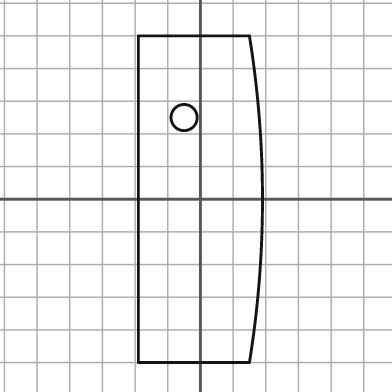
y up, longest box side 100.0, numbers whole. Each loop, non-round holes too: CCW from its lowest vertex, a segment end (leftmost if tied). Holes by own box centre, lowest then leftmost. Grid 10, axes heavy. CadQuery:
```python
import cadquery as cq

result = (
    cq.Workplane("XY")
    .moveTo(-19.0, -50.0)
    .lineTo(15.0, -50.0)
    .threePointArc((19.0, 0.0), (15.0, 50.0))
    .lineTo(-19.0, 50.0)
    .close()
    .moveTo(-5.0, 25.0)
    .circle(4.0)
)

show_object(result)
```